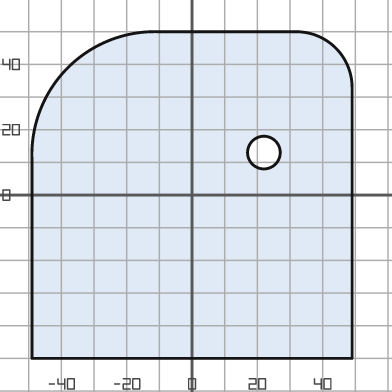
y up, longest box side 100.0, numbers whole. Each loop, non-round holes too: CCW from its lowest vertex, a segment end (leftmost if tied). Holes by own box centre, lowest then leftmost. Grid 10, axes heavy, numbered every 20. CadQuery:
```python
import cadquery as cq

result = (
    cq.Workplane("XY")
    .moveTo(-49.0, -50.0)
    .lineTo(49.0, -50.0)
    .lineTo(49.0, 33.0)
    .threePointArc((44.0, 45.0), (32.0, 50.0))
    .lineTo(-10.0, 50.0)
    .threePointArc((-38.0, 39.0), (-49.0, 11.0))
    .close()
    .moveTo(22.0, 13.0)
    .circle(5.0)
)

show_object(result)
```